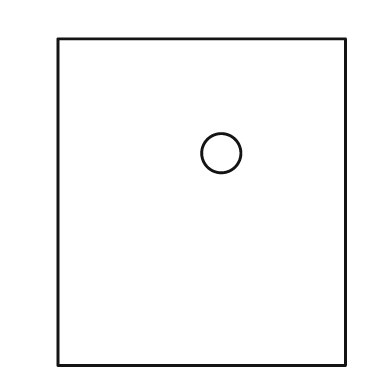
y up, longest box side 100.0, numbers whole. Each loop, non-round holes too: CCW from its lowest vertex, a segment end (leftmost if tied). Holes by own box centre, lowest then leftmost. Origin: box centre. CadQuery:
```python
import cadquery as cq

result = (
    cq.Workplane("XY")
    .moveTo(-44.0, -50.0)
    .lineTo(44.0, -50.0)
    .lineTo(44.0, 50.0)
    .lineTo(-44.0, 50.0)
    .close()
    .moveTo(6.0, 15.0)
    .circle(6.0)
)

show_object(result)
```